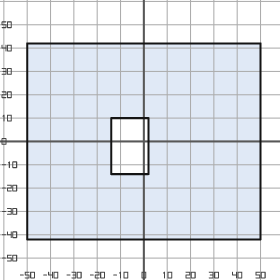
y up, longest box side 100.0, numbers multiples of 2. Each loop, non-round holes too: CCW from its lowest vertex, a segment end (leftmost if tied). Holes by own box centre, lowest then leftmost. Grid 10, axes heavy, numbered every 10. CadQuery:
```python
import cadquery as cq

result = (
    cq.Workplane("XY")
    .moveTo(-50.0, -42.0)
    .lineTo(50.0, -42.0)
    .lineTo(50.0, 42.0)
    .lineTo(-50.0, 42.0)
    .close()
    .moveTo(-14.0, -14.0)
    .lineTo(2.0, -14.0)
    .lineTo(2.0, 10.0)
    .lineTo(-14.0, 10.0)
    .close()
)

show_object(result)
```